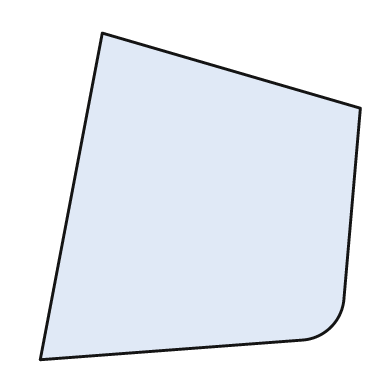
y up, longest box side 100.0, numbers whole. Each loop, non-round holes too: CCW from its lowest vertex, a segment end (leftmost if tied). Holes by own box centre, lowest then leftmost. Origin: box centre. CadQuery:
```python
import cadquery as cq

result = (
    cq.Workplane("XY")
    .moveTo(-49.0, -50.0)
    .lineTo(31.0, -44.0)
    .threePointArc((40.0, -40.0), (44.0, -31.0))
    .lineTo(49.0, 27.0)
    .lineTo(-30.0, 50.0)
    .close()
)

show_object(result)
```